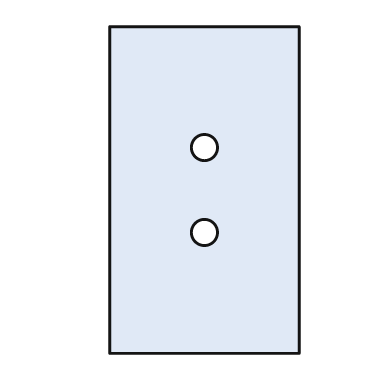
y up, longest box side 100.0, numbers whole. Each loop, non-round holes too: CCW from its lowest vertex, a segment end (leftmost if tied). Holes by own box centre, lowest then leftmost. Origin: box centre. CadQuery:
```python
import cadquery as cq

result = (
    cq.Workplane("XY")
    .moveTo(-29.0, -50.0)
    .lineTo(29.0, -50.0)
    .lineTo(29.0, 50.0)
    .lineTo(-29.0, 50.0)
    .close()
    .moveTo(0.0, -13.0)
    .circle(4.0)
    .moveTo(0.0, 13.0)
    .circle(4.0)
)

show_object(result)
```